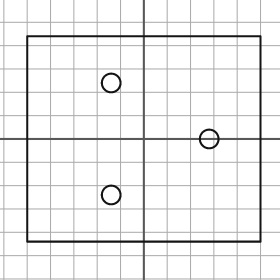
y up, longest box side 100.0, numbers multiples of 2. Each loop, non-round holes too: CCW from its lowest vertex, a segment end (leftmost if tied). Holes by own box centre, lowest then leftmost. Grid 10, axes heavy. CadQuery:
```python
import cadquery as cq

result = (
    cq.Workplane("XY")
    .moveTo(-50.0, -44.0)
    .lineTo(50.0, -44.0)
    .lineTo(50.0, 44.0)
    .lineTo(-50.0, 44.0)
    .close()
    .moveTo(-14.0, -24.0)
    .circle(4.0)
    .moveTo(28.0, 0.0)
    .circle(4.0)
    .moveTo(-14.0, 24.0)
    .circle(4.0)
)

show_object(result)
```